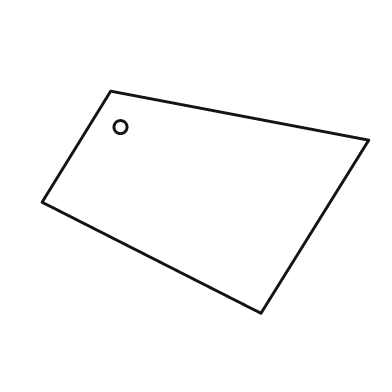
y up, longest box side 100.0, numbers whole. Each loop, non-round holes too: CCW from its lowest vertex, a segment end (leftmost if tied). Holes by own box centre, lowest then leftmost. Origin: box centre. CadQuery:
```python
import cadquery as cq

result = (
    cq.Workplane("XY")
    .moveTo(17.0, -34.0)
    .lineTo(50.0, 19.0)
    .lineTo(-29.0, 34.0)
    .lineTo(-50.0, 0.0)
    .close()
    .moveTo(-26.0, 23.0)
    .circle(2.0)
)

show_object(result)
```